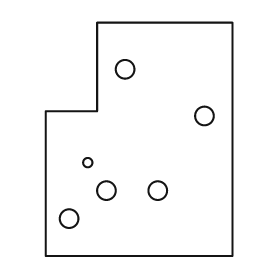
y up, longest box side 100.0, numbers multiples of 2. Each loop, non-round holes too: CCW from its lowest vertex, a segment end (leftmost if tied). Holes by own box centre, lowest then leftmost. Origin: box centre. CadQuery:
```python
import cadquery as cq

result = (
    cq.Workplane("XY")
    .moveTo(-40.0, -50.0)
    .lineTo(40.0, -50.0)
    .lineTo(40.0, 50.0)
    .lineTo(-18.0, 50.0)
    .lineTo(-18.0, 12.0)
    .lineTo(-40.0, 12.0)
    .close()
    .moveTo(-30.0, -34.0)
    .circle(4.0)
    .moveTo(-14.0, -22.0)
    .circle(4.0)
    .moveTo(8.0, -22.0)
    .circle(4.0)
    .moveTo(-22.0, -10.0)
    .circle(2.0)
    .moveTo(28.0, 10.0)
    .circle(4.0)
    .moveTo(-6.0, 30.0)
    .circle(4.0)
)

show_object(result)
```